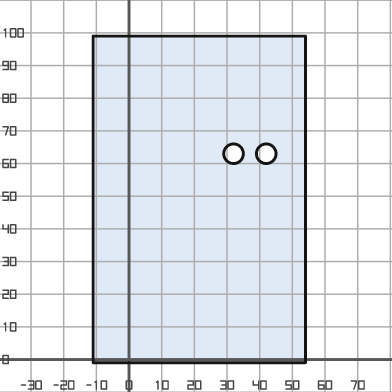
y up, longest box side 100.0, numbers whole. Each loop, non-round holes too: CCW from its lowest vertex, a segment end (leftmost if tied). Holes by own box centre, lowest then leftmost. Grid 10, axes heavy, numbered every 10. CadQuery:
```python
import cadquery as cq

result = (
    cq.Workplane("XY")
    .moveTo(-11.0, -1.0)
    .lineTo(54.0, -1.0)
    .lineTo(54.0, 99.0)
    .lineTo(-11.0, 99.0)
    .close()
    .moveTo(32.0, 63.0)
    .circle(3.0)
    .moveTo(42.0, 63.0)
    .circle(3.0)
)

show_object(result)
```